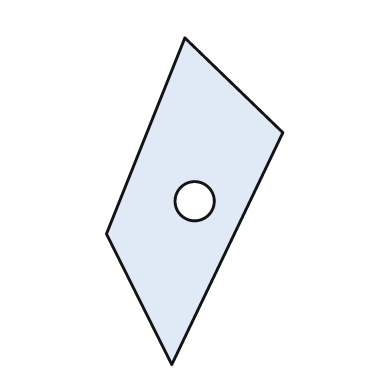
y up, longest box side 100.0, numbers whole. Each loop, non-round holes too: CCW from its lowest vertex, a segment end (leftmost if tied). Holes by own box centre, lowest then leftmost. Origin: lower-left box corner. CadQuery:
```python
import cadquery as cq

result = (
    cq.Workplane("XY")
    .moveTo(20.0, 0.0)
    .lineTo(54.0, 71.0)
    .lineTo(24.0, 100.0)
    .lineTo(0.0, 40.0)
    .close()
    .moveTo(27.0, 50.0)
    .circle(6.0)
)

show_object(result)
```